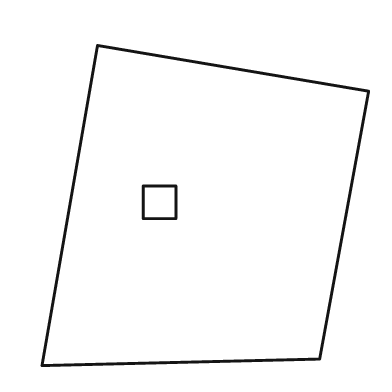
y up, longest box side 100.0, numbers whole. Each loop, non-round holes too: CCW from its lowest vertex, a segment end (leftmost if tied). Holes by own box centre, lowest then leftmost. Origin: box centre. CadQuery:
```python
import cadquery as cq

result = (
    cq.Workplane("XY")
    .moveTo(-50.0, -49.0)
    .lineTo(35.0, -47.0)
    .lineTo(50.0, 35.0)
    .lineTo(-33.0, 49.0)
    .close()
    .moveTo(-19.0, -4.0)
    .lineTo(-9.0, -4.0)
    .lineTo(-9.0, 6.0)
    .lineTo(-19.0, 6.0)
    .close()
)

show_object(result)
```